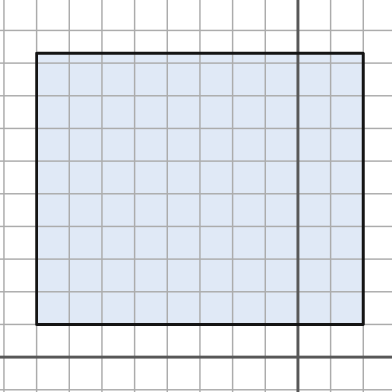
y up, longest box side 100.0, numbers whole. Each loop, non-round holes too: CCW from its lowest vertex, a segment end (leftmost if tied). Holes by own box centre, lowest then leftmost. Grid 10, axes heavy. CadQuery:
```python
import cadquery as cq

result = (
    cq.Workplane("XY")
    .moveTo(-80.0, 10.0)
    .lineTo(20.0, 10.0)
    .lineTo(20.0, 93.0)
    .lineTo(-80.0, 93.0)
    .close()
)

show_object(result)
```